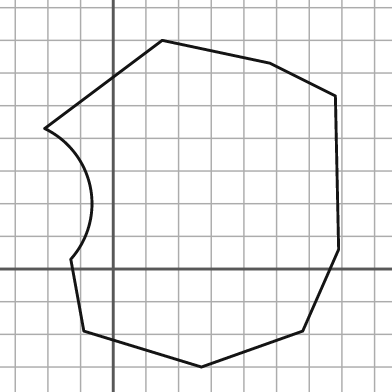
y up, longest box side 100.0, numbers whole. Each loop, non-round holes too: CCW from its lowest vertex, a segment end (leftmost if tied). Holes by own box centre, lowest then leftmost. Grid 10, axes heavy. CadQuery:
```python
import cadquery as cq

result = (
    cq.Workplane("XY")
    .moveTo(27.0, -30.0)
    .lineTo(58.0, -19.0)
    .lineTo(69.0, 6.0)
    .lineTo(68.0, 53.0)
    .lineTo(48.0, 63.0)
    .lineTo(15.0, 70.0)
    .lineTo(-21.0, 43.0)
    .threePointArc((-7.0, 25.0), (-13.0, 3.0))
    .lineTo(-9.0, -19.0)
    .close()
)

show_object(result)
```